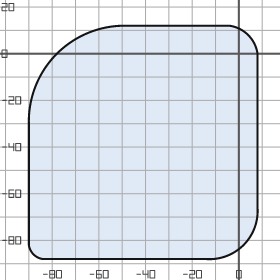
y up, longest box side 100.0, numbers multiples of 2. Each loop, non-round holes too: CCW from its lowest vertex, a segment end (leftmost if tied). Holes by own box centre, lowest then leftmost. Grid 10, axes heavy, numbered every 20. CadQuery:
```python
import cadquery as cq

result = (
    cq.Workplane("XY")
    .moveTo(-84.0, -88.0)
    .lineTo(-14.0, -88.0)
    .threePointArc((2.0, -82.0), (8.0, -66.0))
    .lineTo(8.0, 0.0)
    .threePointArc((4.0, 8.0), (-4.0, 12.0))
    .lineTo(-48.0, 12.0)
    .threePointArc((-78.0, 0.0), (-90.0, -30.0))
    .lineTo(-90.0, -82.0)
    .threePointArc((-88.0, -86.0), (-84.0, -88.0))
    .close()
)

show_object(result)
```